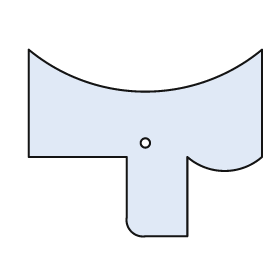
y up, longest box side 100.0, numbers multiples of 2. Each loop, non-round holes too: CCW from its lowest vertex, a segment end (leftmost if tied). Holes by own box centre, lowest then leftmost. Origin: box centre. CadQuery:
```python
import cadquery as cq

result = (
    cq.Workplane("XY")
    .moveTo(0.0, -40.0)
    .lineTo(18.0, -40.0)
    .lineTo(18.0, -6.0)
    .threePointArc((34.0, -12.0), (50.0, -6.0))
    .lineTo(50.0, 40.0)
    .threePointArc((0.0, 22.0), (-50.0, 40.0))
    .lineTo(-50.0, -6.0)
    .lineTo(-8.0, -6.0)
    .lineTo(-8.0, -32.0)
    .threePointArc((-6.0, -38.0), (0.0, -40.0))
    .close()
    .moveTo(0.0, 0.0)
    .circle(2.0)
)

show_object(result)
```